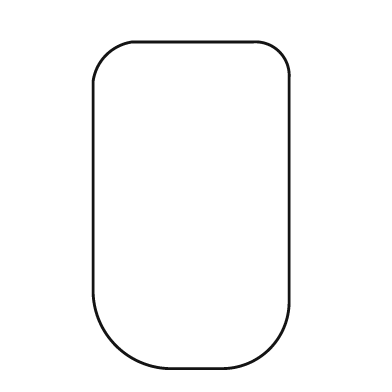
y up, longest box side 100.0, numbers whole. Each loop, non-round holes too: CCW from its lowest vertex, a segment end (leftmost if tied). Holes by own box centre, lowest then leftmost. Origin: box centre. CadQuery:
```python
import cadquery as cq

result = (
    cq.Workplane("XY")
    .moveTo(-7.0, -50.0)
    .lineTo(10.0, -50.0)
    .threePointArc((24.0, -44.0), (30.0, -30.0))
    .lineTo(30.0, 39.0)
    .threePointArc((27.0, 47.0), (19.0, 50.0))
    .lineTo(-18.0, 50.0)
    .threePointArc((-26.0, 46.0), (-30.0, 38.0))
    .lineTo(-30.0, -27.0)
    .threePointArc((-23.0, -43.0), (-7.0, -50.0))
    .close()
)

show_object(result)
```